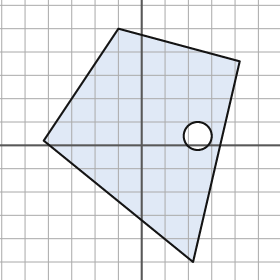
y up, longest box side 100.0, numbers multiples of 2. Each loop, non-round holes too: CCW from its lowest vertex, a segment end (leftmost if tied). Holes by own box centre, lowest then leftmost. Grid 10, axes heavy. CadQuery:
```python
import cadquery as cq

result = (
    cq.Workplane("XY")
    .moveTo(22.0, -50.0)
    .lineTo(42.0, 36.0)
    .lineTo(-10.0, 50.0)
    .lineTo(-42.0, 2.0)
    .close()
    .moveTo(24.0, 4.0)
    .circle(6.0)
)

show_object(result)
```